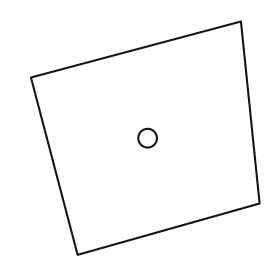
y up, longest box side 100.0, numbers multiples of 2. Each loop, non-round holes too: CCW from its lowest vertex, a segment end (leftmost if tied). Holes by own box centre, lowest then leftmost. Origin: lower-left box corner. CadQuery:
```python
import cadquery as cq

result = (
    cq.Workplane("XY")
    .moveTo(20.0, 0.0)
    .lineTo(98.0, 22.0)
    .lineTo(90.0, 100.0)
    .lineTo(0.0, 76.0)
    .close()
    .moveTo(50.0, 50.0)
    .circle(4.0)
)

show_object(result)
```